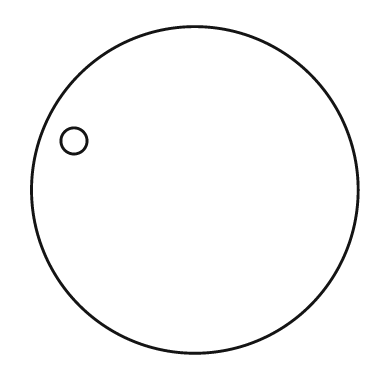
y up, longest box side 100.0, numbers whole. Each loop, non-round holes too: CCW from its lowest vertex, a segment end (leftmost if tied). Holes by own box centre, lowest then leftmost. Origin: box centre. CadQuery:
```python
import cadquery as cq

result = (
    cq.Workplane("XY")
    .moveTo(0.0, 0.0)
    .circle(50.0)
    .moveTo(-37.0, 15.0)
    .circle(4.0)
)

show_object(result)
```